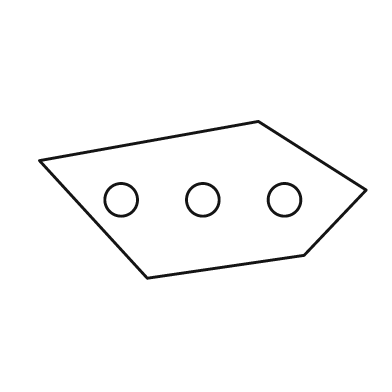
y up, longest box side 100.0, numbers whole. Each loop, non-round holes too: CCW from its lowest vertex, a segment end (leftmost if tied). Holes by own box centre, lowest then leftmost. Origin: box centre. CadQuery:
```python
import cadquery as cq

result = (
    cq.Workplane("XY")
    .moveTo(-17.0, -24.0)
    .lineTo(31.0, -17.0)
    .lineTo(50.0, 3.0)
    .lineTo(17.0, 24.0)
    .lineTo(-50.0, 12.0)
    .close()
    .moveTo(-25.0, 0.0)
    .circle(5.0)
    .moveTo(0.0, 0.0)
    .circle(5.0)
    .moveTo(25.0, 0.0)
    .circle(5.0)
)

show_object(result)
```